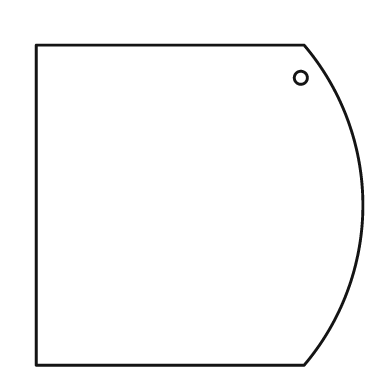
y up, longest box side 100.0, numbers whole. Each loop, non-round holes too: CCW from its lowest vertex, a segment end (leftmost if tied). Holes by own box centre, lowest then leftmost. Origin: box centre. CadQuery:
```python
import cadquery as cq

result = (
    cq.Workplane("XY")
    .moveTo(-50.0, -49.0)
    .lineTo(32.0, -49.0)
    .threePointArc((50.0, 0.0), (32.0, 49.0))
    .lineTo(-50.0, 49.0)
    .close()
    .moveTo(31.0, 39.0)
    .circle(2.0)
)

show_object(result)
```